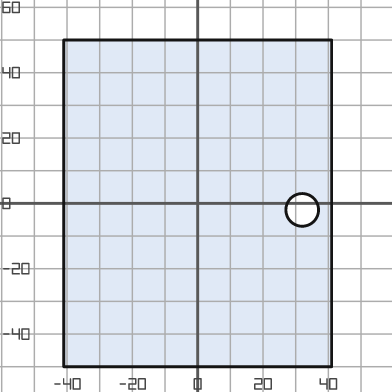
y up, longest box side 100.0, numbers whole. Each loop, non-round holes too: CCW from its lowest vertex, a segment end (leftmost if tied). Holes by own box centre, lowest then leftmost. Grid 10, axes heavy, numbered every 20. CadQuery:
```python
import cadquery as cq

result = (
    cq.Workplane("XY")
    .moveTo(-41.0, -50.0)
    .lineTo(41.0, -50.0)
    .lineTo(41.0, 50.0)
    .lineTo(-41.0, 50.0)
    .close()
    .moveTo(32.0, -2.0)
    .circle(5.0)
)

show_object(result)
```